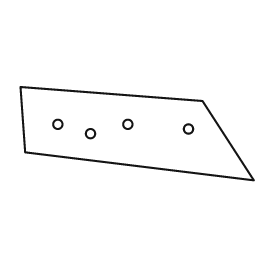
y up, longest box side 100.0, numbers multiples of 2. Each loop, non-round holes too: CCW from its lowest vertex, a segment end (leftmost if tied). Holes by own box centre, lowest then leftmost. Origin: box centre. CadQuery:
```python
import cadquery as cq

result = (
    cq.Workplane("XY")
    .moveTo(50.0, -20.0)
    .lineTo(28.0, 14.0)
    .lineTo(-50.0, 20.0)
    .lineTo(-48.0, -8.0)
    .close()
    .moveTo(-20.0, 0.0)
    .circle(2.0)
    .moveTo(22.0, 2.0)
    .circle(2.0)
    .moveTo(-34.0, 4.0)
    .circle(2.0)
    .moveTo(-4.0, 4.0)
    .circle(2.0)
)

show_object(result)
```